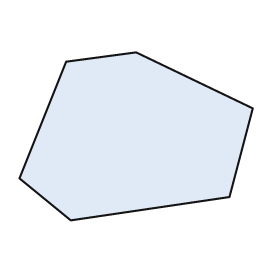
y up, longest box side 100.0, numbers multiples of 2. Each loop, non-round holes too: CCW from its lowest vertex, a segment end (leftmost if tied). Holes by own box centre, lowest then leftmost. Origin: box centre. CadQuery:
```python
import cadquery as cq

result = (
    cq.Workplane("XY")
    .moveTo(-28.0, -36.0)
    .lineTo(40.0, -26.0)
    .lineTo(50.0, 12.0)
    .lineTo(0.0, 36.0)
    .lineTo(-30.0, 32.0)
    .lineTo(-50.0, -18.0)
    .close()
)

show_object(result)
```